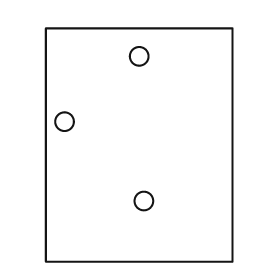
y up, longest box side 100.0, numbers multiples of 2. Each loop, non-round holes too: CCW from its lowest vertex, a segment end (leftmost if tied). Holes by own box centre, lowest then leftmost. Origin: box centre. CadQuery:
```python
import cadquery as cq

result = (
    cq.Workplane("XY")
    .moveTo(-40.0, -50.0)
    .lineTo(40.0, -50.0)
    .lineTo(40.0, 50.0)
    .lineTo(-40.0, 50.0)
    .close()
    .moveTo(2.0, -24.0)
    .circle(4.0)
    .moveTo(-32.0, 10.0)
    .circle(4.0)
    .moveTo(0.0, 38.0)
    .circle(4.0)
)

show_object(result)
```